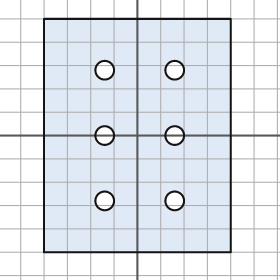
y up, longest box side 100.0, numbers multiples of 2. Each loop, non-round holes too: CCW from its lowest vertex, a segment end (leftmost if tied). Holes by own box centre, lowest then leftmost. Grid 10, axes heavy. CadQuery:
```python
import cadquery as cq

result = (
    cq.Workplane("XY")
    .moveTo(-40.0, -50.0)
    .lineTo(40.0, -50.0)
    .lineTo(40.0, 50.0)
    .lineTo(-40.0, 50.0)
    .close()
    .moveTo(-14.0, -28.0)
    .circle(4.0)
    .moveTo(16.0, -28.0)
    .circle(4.0)
    .moveTo(-14.0, 0.0)
    .circle(4.0)
    .moveTo(16.0, 0.0)
    .circle(4.0)
    .moveTo(-14.0, 28.0)
    .circle(4.0)
    .moveTo(16.0, 28.0)
    .circle(4.0)
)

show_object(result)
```